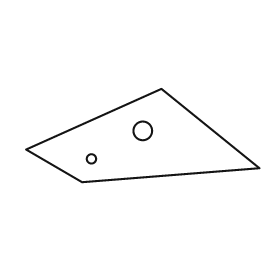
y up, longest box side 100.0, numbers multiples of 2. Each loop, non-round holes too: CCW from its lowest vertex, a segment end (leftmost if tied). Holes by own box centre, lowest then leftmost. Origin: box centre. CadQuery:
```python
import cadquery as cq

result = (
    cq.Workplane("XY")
    .moveTo(-26.0, -20.0)
    .lineTo(50.0, -14.0)
    .lineTo(8.0, 20.0)
    .lineTo(-50.0, -6.0)
    .close()
    .moveTo(-22.0, -10.0)
    .circle(2.0)
    .moveTo(0.0, 2.0)
    .circle(4.0)
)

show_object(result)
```